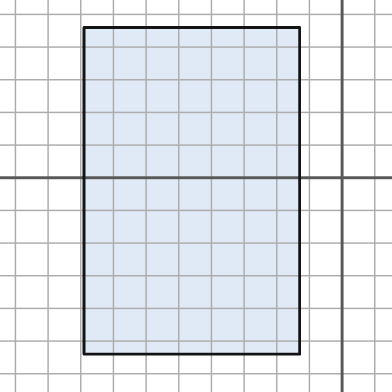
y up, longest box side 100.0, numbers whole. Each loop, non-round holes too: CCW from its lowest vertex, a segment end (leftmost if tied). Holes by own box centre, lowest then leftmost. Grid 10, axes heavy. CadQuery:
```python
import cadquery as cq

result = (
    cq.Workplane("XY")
    .moveTo(-79.0, -54.0)
    .lineTo(-13.0, -54.0)
    .lineTo(-13.0, 46.0)
    .lineTo(-79.0, 46.0)
    .close()
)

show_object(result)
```